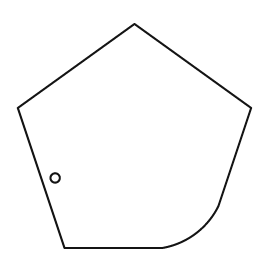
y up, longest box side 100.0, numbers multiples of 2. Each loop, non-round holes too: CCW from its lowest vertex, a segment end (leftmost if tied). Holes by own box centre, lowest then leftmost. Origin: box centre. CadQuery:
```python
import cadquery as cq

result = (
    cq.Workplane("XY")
    .moveTo(-30.0, -48.0)
    .lineTo(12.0, -48.0)
    .threePointArc((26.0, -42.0), (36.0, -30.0))
    .lineTo(50.0, 12.0)
    .lineTo(0.0, 48.0)
    .lineTo(-50.0, 12.0)
    .close()
    .moveTo(-34.0, -18.0)
    .circle(2.0)
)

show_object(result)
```